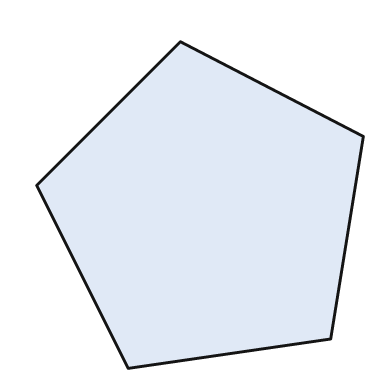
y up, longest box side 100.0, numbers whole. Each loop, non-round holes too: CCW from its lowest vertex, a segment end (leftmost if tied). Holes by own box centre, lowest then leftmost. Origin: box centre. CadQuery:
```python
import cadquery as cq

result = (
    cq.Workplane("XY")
    .moveTo(-22.0, -50.0)
    .lineTo(40.0, -41.0)
    .lineTo(50.0, 21.0)
    .lineTo(-6.0, 50.0)
    .lineTo(-50.0, 6.0)
    .close()
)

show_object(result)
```